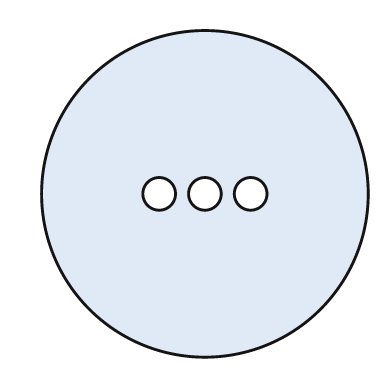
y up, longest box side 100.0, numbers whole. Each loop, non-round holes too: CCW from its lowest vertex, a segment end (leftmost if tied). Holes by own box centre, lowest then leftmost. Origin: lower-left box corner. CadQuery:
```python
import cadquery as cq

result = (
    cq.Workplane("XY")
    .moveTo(50.0, 50.0)
    .circle(50.0)
    .moveTo(36.0, 50.0)
    .circle(5.0)
    .moveTo(50.0, 50.0)
    .circle(5.0)
    .moveTo(64.0, 50.0)
    .circle(5.0)
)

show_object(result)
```